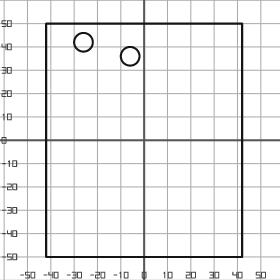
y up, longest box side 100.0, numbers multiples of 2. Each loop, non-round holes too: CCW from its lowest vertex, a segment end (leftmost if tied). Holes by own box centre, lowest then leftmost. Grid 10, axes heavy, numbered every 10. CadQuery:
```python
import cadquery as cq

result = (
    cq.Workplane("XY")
    .moveTo(-42.0, -50.0)
    .lineTo(42.0, -50.0)
    .lineTo(42.0, 50.0)
    .lineTo(-42.0, 50.0)
    .close()
    .moveTo(-6.0, 36.0)
    .circle(4.0)
    .moveTo(-26.0, 42.0)
    .circle(4.0)
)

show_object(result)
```